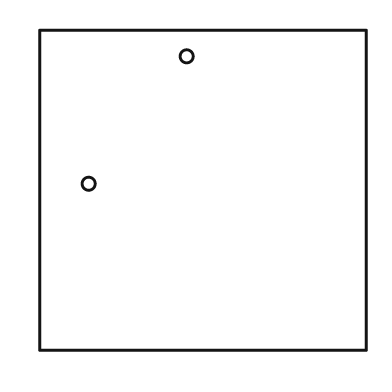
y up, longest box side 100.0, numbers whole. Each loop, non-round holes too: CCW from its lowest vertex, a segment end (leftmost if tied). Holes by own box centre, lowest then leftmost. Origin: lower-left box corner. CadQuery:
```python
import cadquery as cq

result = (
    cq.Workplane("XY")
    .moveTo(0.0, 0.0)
    .lineTo(100.0, 0.0)
    .lineTo(100.0, 98.0)
    .lineTo(0.0, 98.0)
    .close()
    .moveTo(15.0, 51.0)
    .circle(2.0)
    .moveTo(45.0, 90.0)
    .circle(2.0)
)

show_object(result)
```